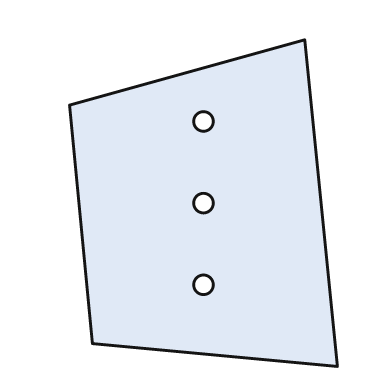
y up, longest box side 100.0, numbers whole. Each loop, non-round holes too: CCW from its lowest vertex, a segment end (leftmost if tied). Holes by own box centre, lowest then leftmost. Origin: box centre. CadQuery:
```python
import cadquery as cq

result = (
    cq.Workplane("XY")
    .moveTo(41.0, -50.0)
    .lineTo(31.0, 50.0)
    .lineTo(-41.0, 30.0)
    .lineTo(-34.0, -43.0)
    .close()
    .moveTo(0.0, -25.0)
    .circle(3.0)
    .moveTo(0.0, 0.0)
    .circle(3.0)
    .moveTo(0.0, 25.0)
    .circle(3.0)
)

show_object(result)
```